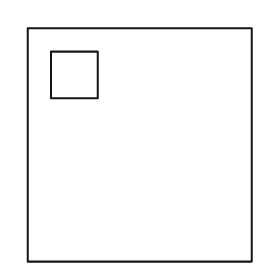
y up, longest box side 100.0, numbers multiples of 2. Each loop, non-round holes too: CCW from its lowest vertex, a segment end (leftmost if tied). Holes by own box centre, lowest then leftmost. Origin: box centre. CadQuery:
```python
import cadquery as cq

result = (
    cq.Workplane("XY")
    .moveTo(-48.0, -50.0)
    .lineTo(48.0, -50.0)
    .lineTo(48.0, 50.0)
    .lineTo(-48.0, 50.0)
    .close()
    .moveTo(-38.0, 20.0)
    .lineTo(-18.0, 20.0)
    .lineTo(-18.0, 40.0)
    .lineTo(-38.0, 40.0)
    .close()
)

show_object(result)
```